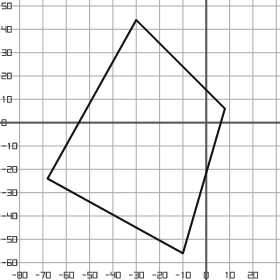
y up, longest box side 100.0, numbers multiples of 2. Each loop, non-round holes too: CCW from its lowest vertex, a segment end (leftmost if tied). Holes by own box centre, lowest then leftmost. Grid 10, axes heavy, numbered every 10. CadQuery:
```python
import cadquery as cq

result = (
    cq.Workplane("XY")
    .moveTo(-10.0, -56.0)
    .lineTo(8.0, 6.0)
    .lineTo(-30.0, 44.0)
    .lineTo(-68.0, -24.0)
    .close()
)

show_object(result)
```